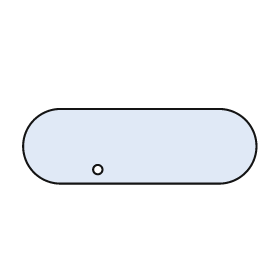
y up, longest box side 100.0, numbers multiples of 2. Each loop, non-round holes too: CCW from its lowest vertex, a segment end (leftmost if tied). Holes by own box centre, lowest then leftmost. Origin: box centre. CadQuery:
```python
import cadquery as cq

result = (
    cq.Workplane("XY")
    .moveTo(-34.0, -16.0)
    .lineTo(34.0, -16.0)
    .threePointArc((50.0, 0.0), (34.0, 16.0))
    .lineTo(-34.0, 16.0)
    .threePointArc((-50.0, 0.0), (-34.0, -16.0))
    .close()
    .moveTo(-18.0, -10.0)
    .circle(2.0)
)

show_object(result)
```